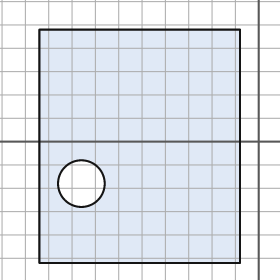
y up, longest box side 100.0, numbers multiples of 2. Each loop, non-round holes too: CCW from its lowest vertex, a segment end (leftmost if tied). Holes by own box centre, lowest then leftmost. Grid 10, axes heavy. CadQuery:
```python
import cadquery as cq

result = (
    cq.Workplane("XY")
    .moveTo(-94.0, -52.0)
    .lineTo(-8.0, -52.0)
    .lineTo(-8.0, 48.0)
    .lineTo(-94.0, 48.0)
    .close()
    .moveTo(-76.0, -18.0)
    .circle(10.0)
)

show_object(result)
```